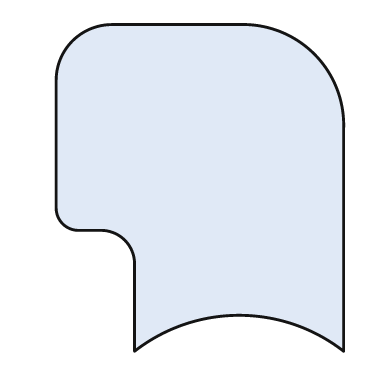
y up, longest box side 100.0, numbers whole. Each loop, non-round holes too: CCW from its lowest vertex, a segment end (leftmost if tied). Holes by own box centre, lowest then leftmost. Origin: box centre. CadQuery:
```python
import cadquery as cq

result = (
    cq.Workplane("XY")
    .moveTo(-20.0, -50.0)
    .threePointArc((12.0, -39.0), (44.0, -50.0))
    .lineTo(44.0, 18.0)
    .threePointArc((35.0, 41.0), (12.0, 50.0))
    .lineTo(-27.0, 50.0)
    .threePointArc((-39.0, 45.0), (-44.0, 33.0))
    .lineTo(-44.0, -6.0)
    .threePointArc((-42.0, -11.0), (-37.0, -13.0))
    .lineTo(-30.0, -13.0)
    .threePointArc((-23.0, -16.0), (-20.0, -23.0))
    .close()
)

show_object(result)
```